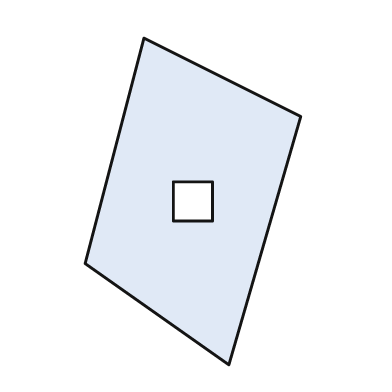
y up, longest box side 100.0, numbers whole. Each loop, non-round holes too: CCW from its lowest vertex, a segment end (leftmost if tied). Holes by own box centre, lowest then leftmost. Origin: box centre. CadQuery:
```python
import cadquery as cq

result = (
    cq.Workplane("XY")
    .moveTo(11.0, -50.0)
    .lineTo(33.0, 26.0)
    .lineTo(-15.0, 50.0)
    .lineTo(-33.0, -19.0)
    .close()
    .moveTo(-6.0, -6.0)
    .lineTo(6.0, -6.0)
    .lineTo(6.0, 6.0)
    .lineTo(-6.0, 6.0)
    .close()
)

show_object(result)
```